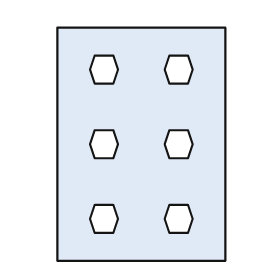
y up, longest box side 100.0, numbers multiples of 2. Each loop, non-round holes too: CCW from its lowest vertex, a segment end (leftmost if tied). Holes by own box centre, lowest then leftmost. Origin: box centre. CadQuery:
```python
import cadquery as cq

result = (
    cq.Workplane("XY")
    .moveTo(-36.0, -50.0)
    .lineTo(36.0, -50.0)
    .lineTo(36.0, 50.0)
    .lineTo(-36.0, 50.0)
    .close()
    .moveTo(-20.0, -38.0)
    .lineTo(-12.0, -38.0)
    .lineTo(-10.0, -32.0)
    .lineTo(-12.0, -26.0)
    .lineTo(-20.0, -26.0)
    .lineTo(-22.0, -32.0)
    .close()
    .moveTo(12.0, -38.0)
    .lineTo(20.0, -38.0)
    .lineTo(22.0, -32.0)
    .lineTo(20.0, -26.0)
    .lineTo(12.0, -26.0)
    .lineTo(10.0, -32.0)
    .close()
    .moveTo(-20.0, -6.0)
    .lineTo(-12.0, -6.0)
    .lineTo(-10.0, 0.0)
    .lineTo(-12.0, 6.0)
    .lineTo(-20.0, 6.0)
    .lineTo(-22.0, 0.0)
    .close()
    .moveTo(12.0, -6.0)
    .lineTo(20.0, -6.0)
    .lineTo(22.0, 0.0)
    .lineTo(20.0, 6.0)
    .lineTo(12.0, 6.0)
    .lineTo(10.0, 0.0)
    .close()
    .moveTo(-20.0, 26.0)
    .lineTo(-12.0, 26.0)
    .lineTo(-10.0, 32.0)
    .lineTo(-12.0, 38.0)
    .lineTo(-20.0, 38.0)
    .lineTo(-22.0, 32.0)
    .close()
    .moveTo(12.0, 26.0)
    .lineTo(20.0, 26.0)
    .lineTo(22.0, 32.0)
    .lineTo(20.0, 38.0)
    .lineTo(12.0, 38.0)
    .lineTo(10.0, 32.0)
    .close()
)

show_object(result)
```